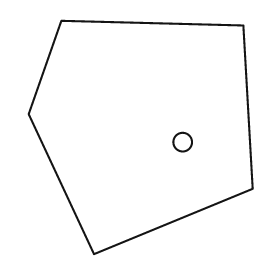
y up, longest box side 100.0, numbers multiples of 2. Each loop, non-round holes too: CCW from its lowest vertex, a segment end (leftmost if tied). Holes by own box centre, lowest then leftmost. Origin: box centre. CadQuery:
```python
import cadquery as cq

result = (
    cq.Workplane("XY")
    .moveTo(-20.0, -50.0)
    .lineTo(48.0, -22.0)
    .lineTo(44.0, 48.0)
    .lineTo(-34.0, 50.0)
    .lineTo(-48.0, 10.0)
    .close()
    .moveTo(18.0, -2.0)
    .circle(4.0)
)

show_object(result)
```